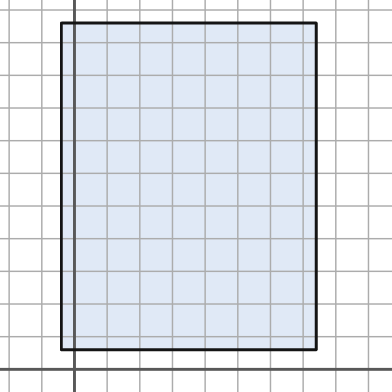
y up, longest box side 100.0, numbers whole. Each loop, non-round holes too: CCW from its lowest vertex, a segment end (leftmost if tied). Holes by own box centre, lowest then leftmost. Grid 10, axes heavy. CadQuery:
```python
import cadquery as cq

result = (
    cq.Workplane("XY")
    .moveTo(-4.0, 6.0)
    .lineTo(74.0, 6.0)
    .lineTo(74.0, 106.0)
    .lineTo(-4.0, 106.0)
    .close()
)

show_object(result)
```